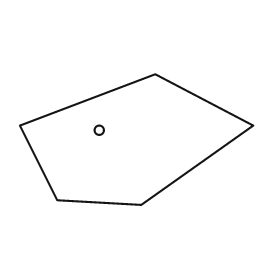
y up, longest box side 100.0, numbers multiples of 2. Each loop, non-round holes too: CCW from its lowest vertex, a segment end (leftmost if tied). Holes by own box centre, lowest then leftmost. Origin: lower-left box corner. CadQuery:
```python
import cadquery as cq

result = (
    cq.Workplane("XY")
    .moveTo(52.0, 0.0)
    .lineTo(100.0, 34.0)
    .lineTo(58.0, 56.0)
    .lineTo(0.0, 34.0)
    .lineTo(16.0, 2.0)
    .close()
    .moveTo(34.0, 32.0)
    .circle(2.0)
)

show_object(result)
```